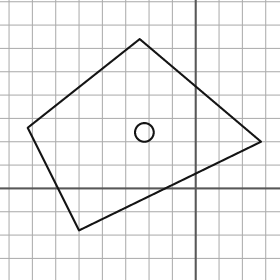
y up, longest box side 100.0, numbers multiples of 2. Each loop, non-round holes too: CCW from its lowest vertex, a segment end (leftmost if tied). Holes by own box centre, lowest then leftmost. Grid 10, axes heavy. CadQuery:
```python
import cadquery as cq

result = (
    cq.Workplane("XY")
    .moveTo(-50.0, -18.0)
    .lineTo(28.0, 20.0)
    .lineTo(-24.0, 64.0)
    .lineTo(-72.0, 26.0)
    .close()
    .moveTo(-22.0, 24.0)
    .circle(4.0)
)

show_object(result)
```